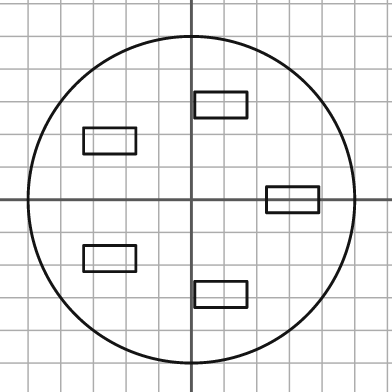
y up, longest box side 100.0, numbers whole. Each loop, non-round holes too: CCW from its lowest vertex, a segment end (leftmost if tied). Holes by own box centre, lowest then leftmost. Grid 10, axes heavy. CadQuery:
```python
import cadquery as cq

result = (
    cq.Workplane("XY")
    .moveTo(0.0, 0.0)
    .circle(50.0)
    .moveTo(1.0, -33.0)
    .lineTo(17.0, -33.0)
    .lineTo(17.0, -25.0)
    .lineTo(1.0, -25.0)
    .close()
    .moveTo(-33.0, -22.0)
    .lineTo(-17.0, -22.0)
    .lineTo(-17.0, -14.0)
    .lineTo(-33.0, -14.0)
    .close()
    .moveTo(23.0, -4.0)
    .lineTo(39.0, -4.0)
    .lineTo(39.0, 4.0)
    .lineTo(23.0, 4.0)
    .close()
    .moveTo(-33.0, 14.0)
    .lineTo(-17.0, 14.0)
    .lineTo(-17.0, 22.0)
    .lineTo(-33.0, 22.0)
    .close()
    .moveTo(1.0, 25.0)
    .lineTo(17.0, 25.0)
    .lineTo(17.0, 33.0)
    .lineTo(1.0, 33.0)
    .close()
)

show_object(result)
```